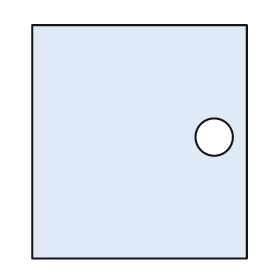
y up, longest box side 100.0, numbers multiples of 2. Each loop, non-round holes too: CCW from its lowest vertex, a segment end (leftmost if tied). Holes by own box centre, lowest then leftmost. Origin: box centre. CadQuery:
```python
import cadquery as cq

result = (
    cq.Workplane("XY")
    .moveTo(-46.0, -50.0)
    .lineTo(46.0, -50.0)
    .lineTo(46.0, 50.0)
    .lineTo(-46.0, 50.0)
    .close()
    .moveTo(32.0, 2.0)
    .circle(8.0)
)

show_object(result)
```